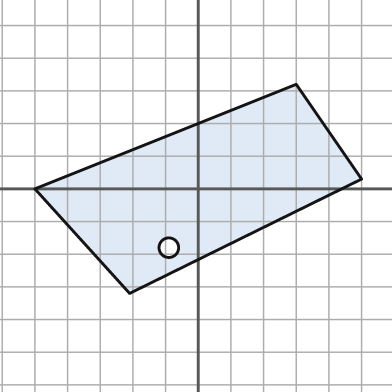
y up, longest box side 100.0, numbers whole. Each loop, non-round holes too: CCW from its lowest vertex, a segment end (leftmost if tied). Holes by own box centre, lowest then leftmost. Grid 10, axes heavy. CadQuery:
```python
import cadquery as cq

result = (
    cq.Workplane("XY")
    .moveTo(-21.0, -32.0)
    .lineTo(50.0, 3.0)
    .lineTo(30.0, 32.0)
    .lineTo(-50.0, 0.0)
    .close()
    .moveTo(-9.0, -18.0)
    .circle(3.0)
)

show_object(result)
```